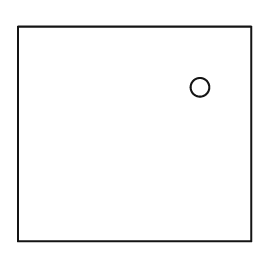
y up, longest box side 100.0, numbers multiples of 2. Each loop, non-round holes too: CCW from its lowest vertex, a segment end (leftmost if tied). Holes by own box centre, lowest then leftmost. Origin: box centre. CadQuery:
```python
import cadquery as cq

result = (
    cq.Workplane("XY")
    .moveTo(-50.0, -46.0)
    .lineTo(50.0, -46.0)
    .lineTo(50.0, 46.0)
    .lineTo(-50.0, 46.0)
    .close()
    .moveTo(28.0, 20.0)
    .circle(4.0)
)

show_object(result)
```